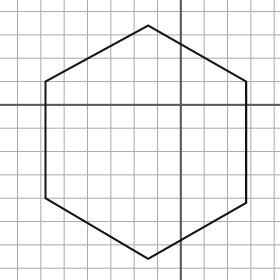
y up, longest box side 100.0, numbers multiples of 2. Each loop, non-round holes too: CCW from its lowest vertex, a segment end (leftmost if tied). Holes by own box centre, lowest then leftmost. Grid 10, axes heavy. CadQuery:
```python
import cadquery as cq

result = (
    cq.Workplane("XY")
    .moveTo(-14.0, -66.0)
    .lineTo(28.0, -42.0)
    .lineTo(28.0, 10.0)
    .lineTo(-14.0, 34.0)
    .lineTo(-58.0, 10.0)
    .lineTo(-58.0, -40.0)
    .close()
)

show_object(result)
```